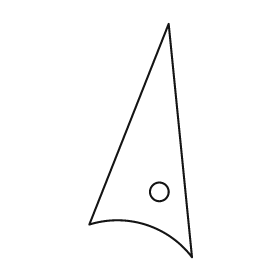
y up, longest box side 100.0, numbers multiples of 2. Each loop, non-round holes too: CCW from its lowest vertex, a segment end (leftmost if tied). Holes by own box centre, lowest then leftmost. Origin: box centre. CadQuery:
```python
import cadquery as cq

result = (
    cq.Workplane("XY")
    .moveTo(22.0, -50.0)
    .lineTo(12.0, 50.0)
    .lineTo(-22.0, -36.0)
    .threePointArc((2.0, -36.0), (22.0, -50.0))
    .close()
    .moveTo(8.0, -22.0)
    .circle(4.0)
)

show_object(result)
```